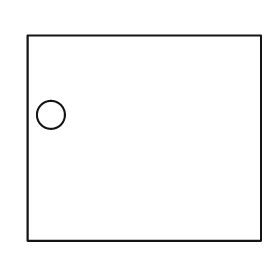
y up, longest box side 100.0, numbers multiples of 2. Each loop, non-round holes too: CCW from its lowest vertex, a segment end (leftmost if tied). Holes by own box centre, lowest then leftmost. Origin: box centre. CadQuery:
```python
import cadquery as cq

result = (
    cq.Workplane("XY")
    .moveTo(-50.0, -44.0)
    .lineTo(50.0, -44.0)
    .lineTo(50.0, 44.0)
    .lineTo(-50.0, 44.0)
    .close()
    .moveTo(-40.0, 10.0)
    .circle(6.0)
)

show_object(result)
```